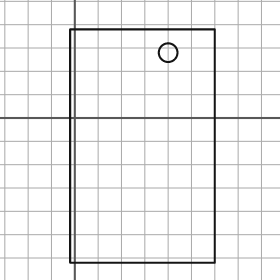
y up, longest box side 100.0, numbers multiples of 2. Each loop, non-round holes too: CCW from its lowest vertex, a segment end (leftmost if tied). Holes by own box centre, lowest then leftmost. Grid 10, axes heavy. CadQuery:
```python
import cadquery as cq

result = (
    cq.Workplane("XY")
    .moveTo(-2.0, -62.0)
    .lineTo(60.0, -62.0)
    .lineTo(60.0, 38.0)
    .lineTo(-2.0, 38.0)
    .close()
    .moveTo(40.0, 28.0)
    .circle(4.0)
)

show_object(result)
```